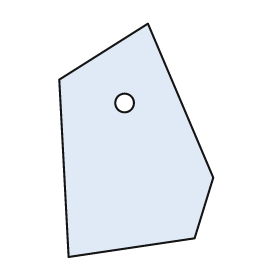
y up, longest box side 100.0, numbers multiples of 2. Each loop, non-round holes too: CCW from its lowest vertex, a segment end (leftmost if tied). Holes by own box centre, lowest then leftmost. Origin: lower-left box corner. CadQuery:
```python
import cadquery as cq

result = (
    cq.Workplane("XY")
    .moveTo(4.0, 0.0)
    .lineTo(58.0, 8.0)
    .lineTo(66.0, 34.0)
    .lineTo(38.0, 100.0)
    .lineTo(0.0, 76.0)
    .close()
    .moveTo(28.0, 66.0)
    .circle(4.0)
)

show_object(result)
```